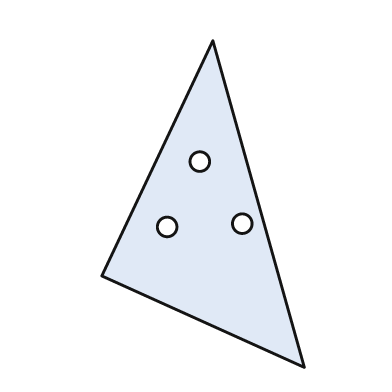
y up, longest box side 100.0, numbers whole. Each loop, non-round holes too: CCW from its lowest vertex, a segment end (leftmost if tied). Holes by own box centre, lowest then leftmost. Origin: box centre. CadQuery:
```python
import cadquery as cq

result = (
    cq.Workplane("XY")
    .moveTo(31.0, -50.0)
    .lineTo(3.0, 50.0)
    .lineTo(-31.0, -22.0)
    .close()
    .moveTo(-11.0, -7.0)
    .circle(3.0)
    .moveTo(12.0, -6.0)
    .circle(3.0)
    .moveTo(-1.0, 13.0)
    .circle(3.0)
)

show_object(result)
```